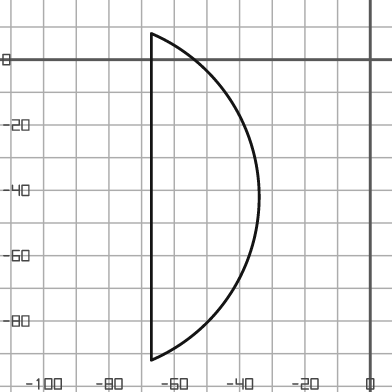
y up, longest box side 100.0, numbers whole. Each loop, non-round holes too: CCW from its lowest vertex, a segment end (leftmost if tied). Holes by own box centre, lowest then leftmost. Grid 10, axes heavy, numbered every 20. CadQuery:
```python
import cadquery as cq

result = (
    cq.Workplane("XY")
    .moveTo(-67.0, -92.0)
    .threePointArc((-34.0, -42.0), (-67.0, 8.0))
    .close()
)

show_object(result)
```